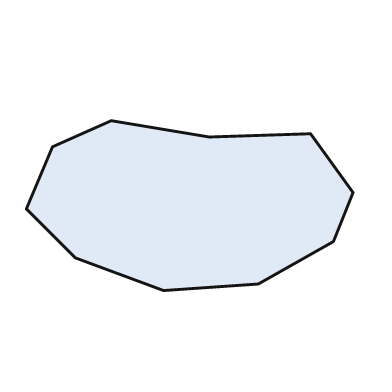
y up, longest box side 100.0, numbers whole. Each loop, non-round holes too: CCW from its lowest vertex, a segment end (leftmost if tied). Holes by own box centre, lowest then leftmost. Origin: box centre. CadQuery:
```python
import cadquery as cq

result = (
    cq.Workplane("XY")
    .moveTo(-8.0, -26.0)
    .lineTo(21.0, -24.0)
    .lineTo(44.0, -11.0)
    .lineTo(50.0, 4.0)
    .lineTo(37.0, 22.0)
    .lineTo(6.0, 21.0)
    .lineTo(-24.0, 26.0)
    .lineTo(-42.0, 18.0)
    .lineTo(-50.0, -1.0)
    .lineTo(-35.0, -16.0)
    .close()
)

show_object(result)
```